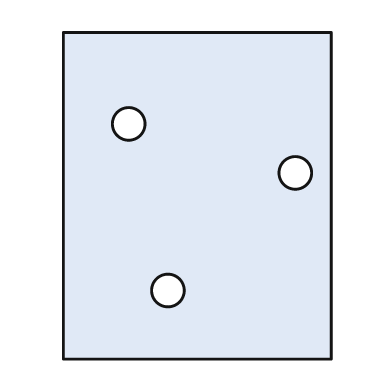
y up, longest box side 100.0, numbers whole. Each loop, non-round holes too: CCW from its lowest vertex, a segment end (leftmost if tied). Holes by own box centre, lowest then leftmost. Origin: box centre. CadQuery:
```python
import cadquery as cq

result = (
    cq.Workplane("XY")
    .moveTo(-41.0, -50.0)
    .lineTo(41.0, -50.0)
    .lineTo(41.0, 50.0)
    .lineTo(-41.0, 50.0)
    .close()
    .moveTo(-9.0, -29.0)
    .circle(5.0)
    .moveTo(30.0, 7.0)
    .circle(5.0)
    .moveTo(-21.0, 22.0)
    .circle(5.0)
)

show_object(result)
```